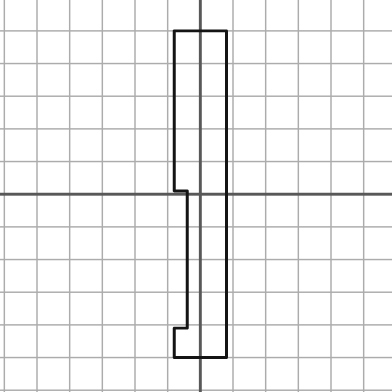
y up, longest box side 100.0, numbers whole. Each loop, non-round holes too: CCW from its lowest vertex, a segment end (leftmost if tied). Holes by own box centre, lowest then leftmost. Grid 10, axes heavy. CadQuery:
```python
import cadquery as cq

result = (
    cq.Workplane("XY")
    .moveTo(-8.0, -50.0)
    .lineTo(8.0, -50.0)
    .lineTo(8.0, 50.0)
    .lineTo(-8.0, 50.0)
    .lineTo(-8.0, 1.0)
    .lineTo(-4.0, 1.0)
    .lineTo(-4.0, -41.0)
    .lineTo(-8.0, -41.0)
    .close()
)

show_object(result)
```